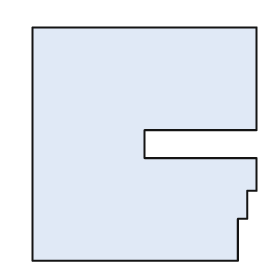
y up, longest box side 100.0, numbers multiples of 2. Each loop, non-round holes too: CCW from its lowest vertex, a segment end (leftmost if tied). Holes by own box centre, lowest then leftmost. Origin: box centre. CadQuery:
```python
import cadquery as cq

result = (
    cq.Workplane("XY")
    .moveTo(-48.0, -50.0)
    .lineTo(40.0, -50.0)
    .lineTo(40.0, -32.0)
    .lineTo(44.0, -32.0)
    .lineTo(44.0, -20.0)
    .lineTo(48.0, -20.0)
    .lineTo(48.0, -6.0)
    .lineTo(0.0, -6.0)
    .lineTo(0.0, 6.0)
    .lineTo(48.0, 6.0)
    .lineTo(48.0, 50.0)
    .lineTo(-48.0, 50.0)
    .close()
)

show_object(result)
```